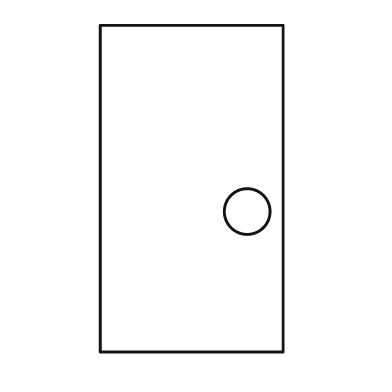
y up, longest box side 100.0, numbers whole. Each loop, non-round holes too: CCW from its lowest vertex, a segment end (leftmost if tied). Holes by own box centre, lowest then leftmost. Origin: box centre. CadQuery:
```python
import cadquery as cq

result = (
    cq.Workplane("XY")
    .moveTo(-28.0, -50.0)
    .lineTo(28.0, -50.0)
    .lineTo(28.0, 50.0)
    .lineTo(-28.0, 50.0)
    .close()
    .moveTo(17.0, -7.0)
    .circle(7.0)
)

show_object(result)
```